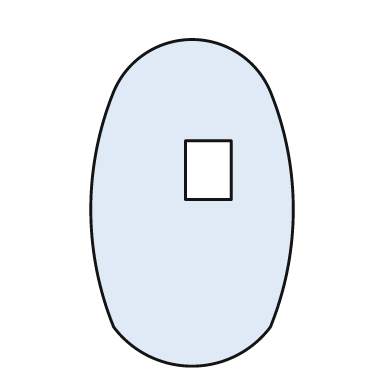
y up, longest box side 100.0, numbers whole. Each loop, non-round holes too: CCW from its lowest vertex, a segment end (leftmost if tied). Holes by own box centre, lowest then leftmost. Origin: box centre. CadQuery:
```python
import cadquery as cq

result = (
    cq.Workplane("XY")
    .moveTo(-24.0, -38.0)
    .threePointArc((0.0, -50.0), (24.0, -38.0))
    .threePointArc((31.0, -2.0), (24.0, 34.0))
    .threePointArc((0.0, 50.0), (-24.0, 34.0))
    .threePointArc((-31.0, -2.0), (-24.0, -38.0))
    .close()
    .moveTo(-2.0, 1.0)
    .lineTo(12.0, 1.0)
    .lineTo(12.0, 19.0)
    .lineTo(-2.0, 19.0)
    .close()
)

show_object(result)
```